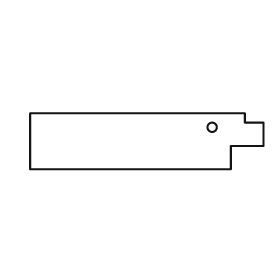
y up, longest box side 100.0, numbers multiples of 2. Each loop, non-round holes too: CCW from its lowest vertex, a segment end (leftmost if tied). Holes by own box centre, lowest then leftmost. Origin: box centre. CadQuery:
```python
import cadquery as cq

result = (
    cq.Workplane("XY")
    .moveTo(-50.0, -12.0)
    .lineTo(36.0, -12.0)
    .lineTo(36.0, -2.0)
    .lineTo(50.0, -2.0)
    .lineTo(50.0, 8.0)
    .lineTo(42.0, 8.0)
    .lineTo(42.0, 12.0)
    .lineTo(-50.0, 12.0)
    .close()
    .moveTo(28.0, 6.0)
    .circle(2.0)
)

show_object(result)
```